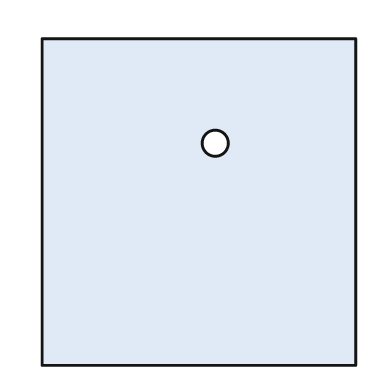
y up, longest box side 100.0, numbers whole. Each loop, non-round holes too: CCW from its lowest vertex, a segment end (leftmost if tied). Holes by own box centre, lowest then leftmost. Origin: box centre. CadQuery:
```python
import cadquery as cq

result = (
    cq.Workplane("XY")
    .moveTo(-48.0, -50.0)
    .lineTo(48.0, -50.0)
    .lineTo(48.0, 50.0)
    .lineTo(-48.0, 50.0)
    .close()
    .moveTo(5.0, 18.0)
    .circle(4.0)
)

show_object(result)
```